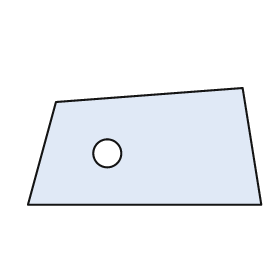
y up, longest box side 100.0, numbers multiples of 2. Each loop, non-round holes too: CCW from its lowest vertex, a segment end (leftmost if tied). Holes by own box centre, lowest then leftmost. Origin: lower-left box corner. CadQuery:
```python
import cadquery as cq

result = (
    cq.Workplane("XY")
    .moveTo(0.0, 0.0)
    .lineTo(100.0, 0.0)
    .lineTo(92.0, 50.0)
    .lineTo(12.0, 44.0)
    .close()
    .moveTo(34.0, 22.0)
    .circle(6.0)
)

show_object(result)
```